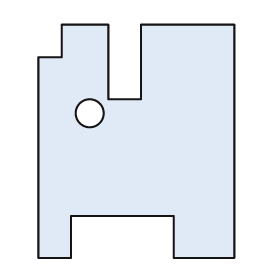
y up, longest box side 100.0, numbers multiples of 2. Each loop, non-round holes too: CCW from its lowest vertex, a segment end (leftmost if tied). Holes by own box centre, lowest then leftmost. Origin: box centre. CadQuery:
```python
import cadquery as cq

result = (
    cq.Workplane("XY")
    .moveTo(-42.0, -50.0)
    .lineTo(-28.0, -50.0)
    .lineTo(-28.0, -32.0)
    .lineTo(16.0, -32.0)
    .lineTo(16.0, -50.0)
    .lineTo(42.0, -50.0)
    .lineTo(42.0, 50.0)
    .lineTo(2.0, 50.0)
    .lineTo(2.0, 18.0)
    .lineTo(-12.0, 18.0)
    .lineTo(-12.0, 50.0)
    .lineTo(-32.0, 50.0)
    .lineTo(-32.0, 36.0)
    .lineTo(-42.0, 36.0)
    .close()
    .moveTo(-20.0, 12.0)
    .circle(6.0)
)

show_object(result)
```